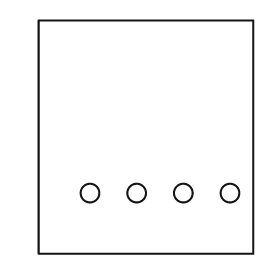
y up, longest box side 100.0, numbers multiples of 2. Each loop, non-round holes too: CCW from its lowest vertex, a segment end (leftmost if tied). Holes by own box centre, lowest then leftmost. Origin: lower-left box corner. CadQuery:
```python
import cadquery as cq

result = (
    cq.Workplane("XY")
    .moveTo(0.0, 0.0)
    .lineTo(92.0, 0.0)
    .lineTo(92.0, 100.0)
    .lineTo(0.0, 100.0)
    .close()
    .moveTo(22.0, 26.0)
    .circle(4.0)
    .moveTo(42.0, 26.0)
    .circle(4.0)
    .moveTo(62.0, 26.0)
    .circle(4.0)
    .moveTo(82.0, 26.0)
    .circle(4.0)
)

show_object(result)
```